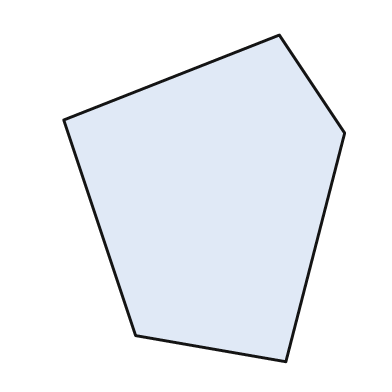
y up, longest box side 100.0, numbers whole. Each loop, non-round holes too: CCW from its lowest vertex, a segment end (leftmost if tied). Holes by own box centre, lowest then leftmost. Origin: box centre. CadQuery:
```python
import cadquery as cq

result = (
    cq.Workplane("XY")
    .moveTo(25.0, -50.0)
    .lineTo(43.0, 20.0)
    .lineTo(23.0, 50.0)
    .lineTo(-43.0, 24.0)
    .lineTo(-21.0, -42.0)
    .close()
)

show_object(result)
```